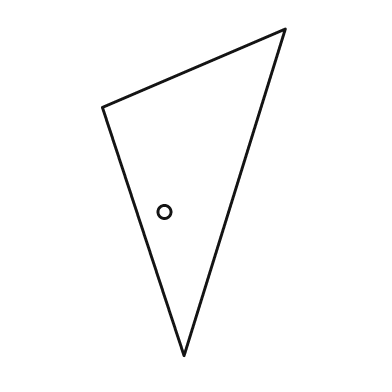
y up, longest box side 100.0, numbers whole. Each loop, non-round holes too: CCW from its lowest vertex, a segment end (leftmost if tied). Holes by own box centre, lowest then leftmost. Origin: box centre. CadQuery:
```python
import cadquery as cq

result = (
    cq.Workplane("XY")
    .moveTo(-3.0, -50.0)
    .lineTo(28.0, 50.0)
    .lineTo(-28.0, 26.0)
    .close()
    .moveTo(-9.0, -6.0)
    .circle(2.0)
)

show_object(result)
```